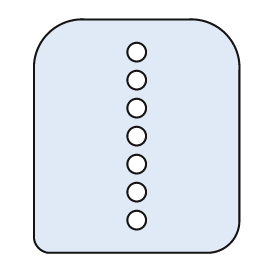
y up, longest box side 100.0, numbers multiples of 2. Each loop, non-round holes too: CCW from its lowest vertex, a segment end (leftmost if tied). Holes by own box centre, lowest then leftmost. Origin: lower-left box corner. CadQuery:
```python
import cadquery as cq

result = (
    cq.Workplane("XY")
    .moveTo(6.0, 0.0)
    .lineTo(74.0, 0.0)
    .threePointArc((84.0, 4.0), (88.0, 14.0))
    .lineTo(88.0, 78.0)
    .threePointArc((82.0, 94.0), (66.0, 100.0))
    .lineTo(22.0, 100.0)
    .threePointArc((6.0, 94.0), (0.0, 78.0))
    .lineTo(0.0, 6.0)
    .threePointArc((2.0, 2.0), (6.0, 0.0))
    .close()
    .moveTo(44.0, 14.0)
    .circle(4.0)
    .moveTo(44.0, 26.0)
    .circle(4.0)
    .moveTo(44.0, 38.0)
    .circle(4.0)
    .moveTo(44.0, 50.0)
    .circle(4.0)
    .moveTo(44.0, 62.0)
    .circle(4.0)
    .moveTo(44.0, 74.0)
    .circle(4.0)
    .moveTo(44.0, 86.0)
    .circle(4.0)
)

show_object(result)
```